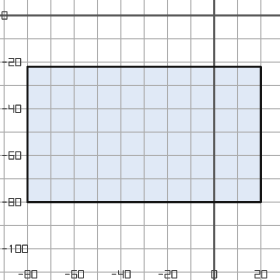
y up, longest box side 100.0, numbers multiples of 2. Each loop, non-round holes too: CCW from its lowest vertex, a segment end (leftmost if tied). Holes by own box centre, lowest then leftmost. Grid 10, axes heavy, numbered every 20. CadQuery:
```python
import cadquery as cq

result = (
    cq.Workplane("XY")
    .moveTo(-80.0, -80.0)
    .lineTo(20.0, -80.0)
    .lineTo(20.0, -22.0)
    .lineTo(-80.0, -22.0)
    .close()
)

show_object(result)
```